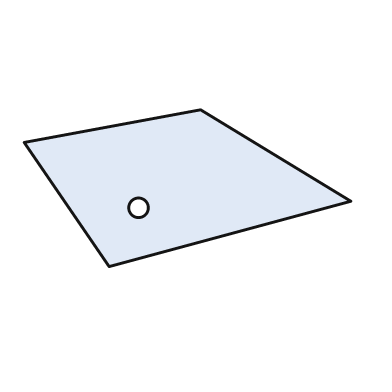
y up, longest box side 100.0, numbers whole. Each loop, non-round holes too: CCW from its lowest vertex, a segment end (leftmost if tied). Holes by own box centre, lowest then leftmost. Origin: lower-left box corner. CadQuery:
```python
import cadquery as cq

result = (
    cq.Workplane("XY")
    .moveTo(26.0, 0.0)
    .lineTo(100.0, 20.0)
    .lineTo(54.0, 48.0)
    .lineTo(0.0, 38.0)
    .close()
    .moveTo(35.0, 18.0)
    .circle(3.0)
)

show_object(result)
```